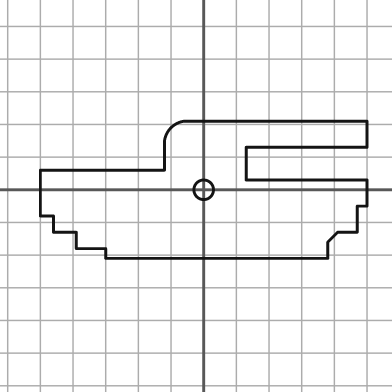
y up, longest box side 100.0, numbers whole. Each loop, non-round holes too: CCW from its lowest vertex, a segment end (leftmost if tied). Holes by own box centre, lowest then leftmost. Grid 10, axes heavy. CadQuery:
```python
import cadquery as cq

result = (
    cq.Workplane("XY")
    .moveTo(-30.0, -21.0)
    .lineTo(38.0, -21.0)
    .lineTo(38.0, -16.0)
    .lineTo(41.0, -13.0)
    .lineTo(47.0, -13.0)
    .lineTo(47.0, -5.0)
    .lineTo(50.0, -5.0)
    .lineTo(50.0, 3.0)
    .lineTo(13.0, 3.0)
    .lineTo(13.0, 13.0)
    .lineTo(50.0, 13.0)
    .lineTo(50.0, 21.0)
    .lineTo(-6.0, 21.0)
    .threePointArc((-10.0, 19.0), (-12.0, 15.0))
    .lineTo(-12.0, 6.0)
    .lineTo(-50.0, 6.0)
    .lineTo(-50.0, -8.0)
    .lineTo(-46.0, -8.0)
    .lineTo(-46.0, -13.0)
    .lineTo(-39.0, -13.0)
    .lineTo(-39.0, -18.0)
    .lineTo(-30.0, -18.0)
    .close()
    .moveTo(0.0, 0.0)
    .circle(3.0)
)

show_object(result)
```